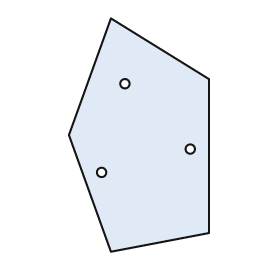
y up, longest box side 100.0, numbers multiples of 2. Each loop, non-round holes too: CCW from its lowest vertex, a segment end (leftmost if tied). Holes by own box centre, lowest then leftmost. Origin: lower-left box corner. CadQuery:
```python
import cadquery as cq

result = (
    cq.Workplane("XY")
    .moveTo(18.0, 0.0)
    .lineTo(60.0, 8.0)
    .lineTo(60.0, 74.0)
    .lineTo(18.0, 100.0)
    .lineTo(0.0, 50.0)
    .close()
    .moveTo(14.0, 34.0)
    .circle(2.0)
    .moveTo(52.0, 44.0)
    .circle(2.0)
    .moveTo(24.0, 72.0)
    .circle(2.0)
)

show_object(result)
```